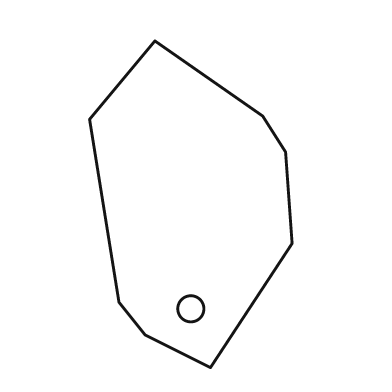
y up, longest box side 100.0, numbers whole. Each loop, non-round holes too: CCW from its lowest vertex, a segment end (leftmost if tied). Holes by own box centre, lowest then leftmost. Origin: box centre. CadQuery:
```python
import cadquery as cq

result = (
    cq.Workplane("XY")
    .moveTo(6.0, -50.0)
    .lineTo(31.0, -12.0)
    .lineTo(29.0, 16.0)
    .lineTo(22.0, 27.0)
    .lineTo(-11.0, 50.0)
    .lineTo(-31.0, 26.0)
    .lineTo(-22.0, -30.0)
    .lineTo(-14.0, -40.0)
    .close()
    .moveTo(0.0, -32.0)
    .circle(4.0)
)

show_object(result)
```